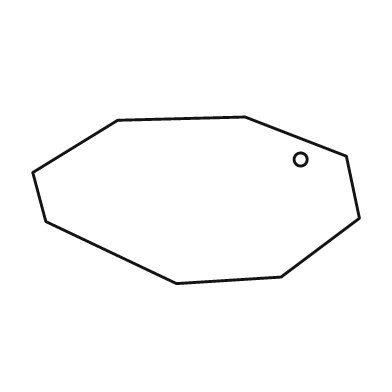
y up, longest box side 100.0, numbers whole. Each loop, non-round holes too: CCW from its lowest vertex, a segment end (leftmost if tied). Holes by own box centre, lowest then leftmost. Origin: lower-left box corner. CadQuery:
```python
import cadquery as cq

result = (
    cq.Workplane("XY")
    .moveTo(44.0, 0.0)
    .lineTo(76.0, 2.0)
    .lineTo(100.0, 20.0)
    .lineTo(96.0, 39.0)
    .lineTo(65.0, 51.0)
    .lineTo(26.0, 50.0)
    .lineTo(0.0, 34.0)
    .lineTo(4.0, 19.0)
    .close()
    .moveTo(82.0, 38.0)
    .circle(2.0)
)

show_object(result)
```